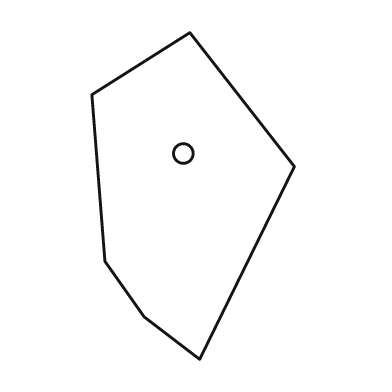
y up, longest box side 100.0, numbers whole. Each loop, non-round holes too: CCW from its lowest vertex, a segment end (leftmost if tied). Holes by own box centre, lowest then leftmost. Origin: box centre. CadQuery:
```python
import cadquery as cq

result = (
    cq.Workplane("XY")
    .moveTo(2.0, -50.0)
    .lineTo(31.0, 9.0)
    .lineTo(-1.0, 50.0)
    .lineTo(-31.0, 31.0)
    .lineTo(-27.0, -20.0)
    .lineTo(-15.0, -37.0)
    .close()
    .moveTo(-3.0, 13.0)
    .circle(3.0)
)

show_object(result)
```